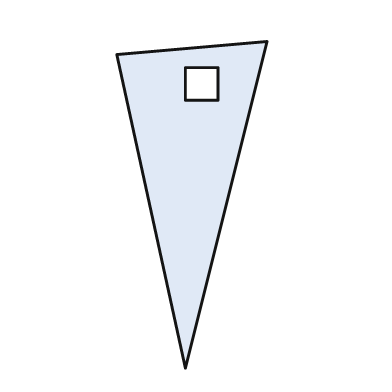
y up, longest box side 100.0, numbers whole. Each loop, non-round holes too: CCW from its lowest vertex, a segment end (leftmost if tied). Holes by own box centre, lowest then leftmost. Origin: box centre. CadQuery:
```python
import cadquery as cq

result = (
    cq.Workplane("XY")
    .moveTo(-2.0, -50.0)
    .lineTo(23.0, 50.0)
    .lineTo(-23.0, 46.0)
    .close()
    .moveTo(-2.0, 32.0)
    .lineTo(8.0, 32.0)
    .lineTo(8.0, 42.0)
    .lineTo(-2.0, 42.0)
    .close()
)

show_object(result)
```